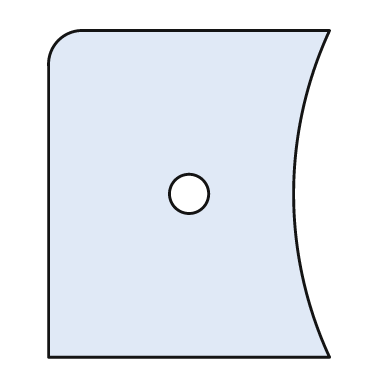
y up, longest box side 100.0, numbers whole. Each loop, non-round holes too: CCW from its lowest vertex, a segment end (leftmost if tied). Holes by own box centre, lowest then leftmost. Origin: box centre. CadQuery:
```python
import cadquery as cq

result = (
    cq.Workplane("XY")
    .moveTo(-43.0, -50.0)
    .lineTo(43.0, -50.0)
    .threePointArc((32.0, 0.0), (43.0, 50.0))
    .lineTo(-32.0, 50.0)
    .threePointArc((-40.0, 47.0), (-43.0, 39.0))
    .close()
    .moveTo(0.0, 0.0)
    .circle(6.0)
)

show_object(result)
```